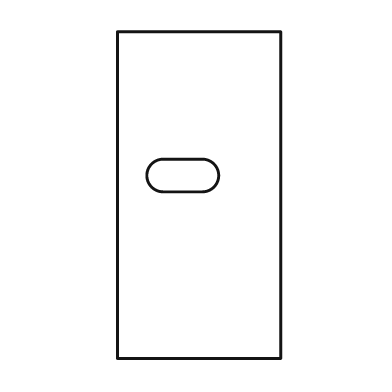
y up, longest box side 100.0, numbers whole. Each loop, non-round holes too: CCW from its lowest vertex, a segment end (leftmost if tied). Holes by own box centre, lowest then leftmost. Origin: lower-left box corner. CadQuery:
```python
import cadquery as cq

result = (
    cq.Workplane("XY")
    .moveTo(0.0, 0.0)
    .lineTo(50.0, 0.0)
    .lineTo(50.0, 100.0)
    .lineTo(0.0, 100.0)
    .close()
    .moveTo(14.0, 51.0)
    .lineTo(26.0, 51.0)
    .threePointArc((31.0, 56.0), (26.0, 61.0))
    .lineTo(14.0, 61.0)
    .threePointArc((9.0, 56.0), (14.0, 51.0))
    .close()
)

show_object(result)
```